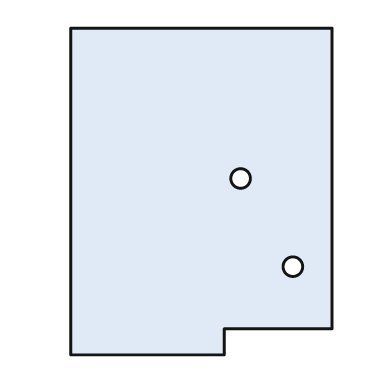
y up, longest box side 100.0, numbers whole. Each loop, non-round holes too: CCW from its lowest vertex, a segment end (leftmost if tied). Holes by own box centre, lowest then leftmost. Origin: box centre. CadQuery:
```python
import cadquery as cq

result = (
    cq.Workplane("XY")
    .moveTo(-40.0, -50.0)
    .lineTo(7.0, -50.0)
    .lineTo(7.0, -42.0)
    .lineTo(40.0, -42.0)
    .lineTo(40.0, 50.0)
    .lineTo(-40.0, 50.0)
    .close()
    .moveTo(28.0, -23.0)
    .circle(3.0)
    .moveTo(12.0, 4.0)
    .circle(3.0)
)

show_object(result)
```